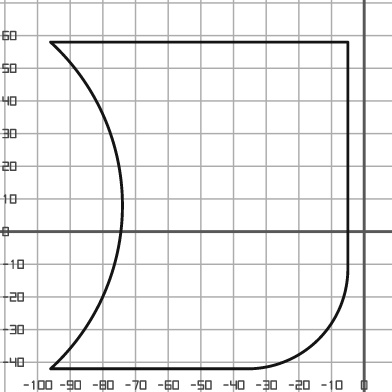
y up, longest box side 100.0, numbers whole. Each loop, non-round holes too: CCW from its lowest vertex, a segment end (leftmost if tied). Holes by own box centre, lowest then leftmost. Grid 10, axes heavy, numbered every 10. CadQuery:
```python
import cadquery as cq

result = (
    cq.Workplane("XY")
    .moveTo(-96.0, -42.0)
    .lineTo(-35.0, -42.0)
    .threePointArc((-14.0, -33.0), (-5.0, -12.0))
    .lineTo(-5.0, 58.0)
    .lineTo(-96.0, 58.0)
    .threePointArc((-74.0, 8.0), (-96.0, -42.0))
    .close()
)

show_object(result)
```